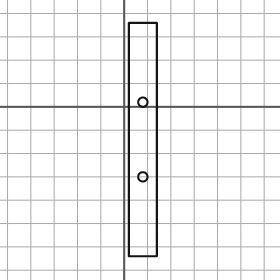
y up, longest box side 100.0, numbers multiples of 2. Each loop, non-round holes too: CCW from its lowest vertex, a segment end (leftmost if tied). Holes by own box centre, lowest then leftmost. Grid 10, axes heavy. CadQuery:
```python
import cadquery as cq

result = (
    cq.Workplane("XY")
    .moveTo(2.0, -64.0)
    .lineTo(14.0, -64.0)
    .lineTo(14.0, 36.0)
    .lineTo(2.0, 36.0)
    .close()
    .moveTo(8.0, -30.0)
    .circle(2.0)
    .moveTo(8.0, 2.0)
    .circle(2.0)
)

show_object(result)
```